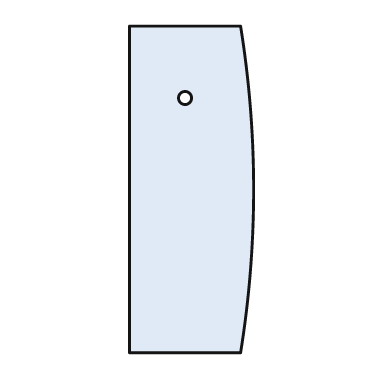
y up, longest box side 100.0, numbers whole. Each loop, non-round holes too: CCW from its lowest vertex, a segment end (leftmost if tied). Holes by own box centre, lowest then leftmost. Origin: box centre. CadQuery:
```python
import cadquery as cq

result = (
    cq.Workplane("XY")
    .moveTo(-19.0, -50.0)
    .lineTo(15.0, -50.0)
    .threePointArc((19.0, 0.0), (15.0, 50.0))
    .lineTo(-19.0, 50.0)
    .close()
    .moveTo(-2.0, 28.0)
    .circle(2.0)
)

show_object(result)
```